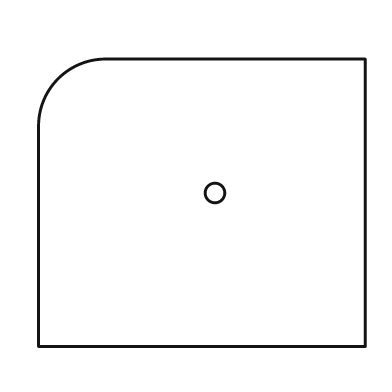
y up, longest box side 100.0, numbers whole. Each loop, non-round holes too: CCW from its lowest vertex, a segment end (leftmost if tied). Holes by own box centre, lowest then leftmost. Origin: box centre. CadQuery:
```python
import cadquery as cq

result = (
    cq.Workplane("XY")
    .moveTo(-50.0, -44.0)
    .lineTo(50.0, -44.0)
    .lineTo(50.0, 44.0)
    .lineTo(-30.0, 44.0)
    .threePointArc((-44.0, 38.0), (-50.0, 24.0))
    .close()
    .moveTo(4.0, 3.0)
    .circle(3.0)
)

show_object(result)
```